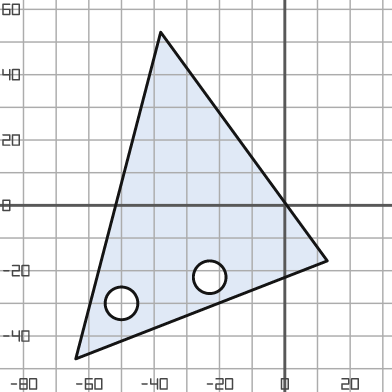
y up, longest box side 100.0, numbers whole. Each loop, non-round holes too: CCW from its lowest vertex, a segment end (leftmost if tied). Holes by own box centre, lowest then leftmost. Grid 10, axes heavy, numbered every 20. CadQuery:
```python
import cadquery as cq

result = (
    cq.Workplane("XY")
    .moveTo(-64.0, -47.0)
    .lineTo(13.0, -17.0)
    .lineTo(-38.0, 53.0)
    .close()
    .moveTo(-50.0, -30.0)
    .circle(5.0)
    .moveTo(-23.0, -22.0)
    .circle(5.0)
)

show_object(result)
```